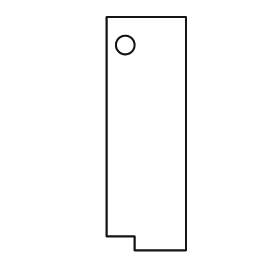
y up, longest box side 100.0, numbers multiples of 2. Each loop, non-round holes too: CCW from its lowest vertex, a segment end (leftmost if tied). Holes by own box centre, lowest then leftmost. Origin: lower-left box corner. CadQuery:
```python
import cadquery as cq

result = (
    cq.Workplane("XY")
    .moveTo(12.0, 0.0)
    .lineTo(34.0, 0.0)
    .lineTo(34.0, 100.0)
    .lineTo(0.0, 100.0)
    .lineTo(0.0, 6.0)
    .lineTo(12.0, 6.0)
    .close()
    .moveTo(8.0, 88.0)
    .circle(4.0)
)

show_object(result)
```